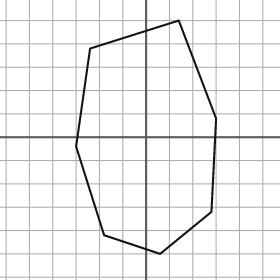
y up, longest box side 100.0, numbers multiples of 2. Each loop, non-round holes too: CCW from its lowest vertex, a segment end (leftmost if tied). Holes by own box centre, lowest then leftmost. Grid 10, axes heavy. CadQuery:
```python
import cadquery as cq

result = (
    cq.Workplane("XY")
    .moveTo(6.0, -50.0)
    .lineTo(28.0, -32.0)
    .lineTo(30.0, 8.0)
    .lineTo(14.0, 50.0)
    .lineTo(-24.0, 38.0)
    .lineTo(-30.0, -4.0)
    .lineTo(-18.0, -42.0)
    .close()
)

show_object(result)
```